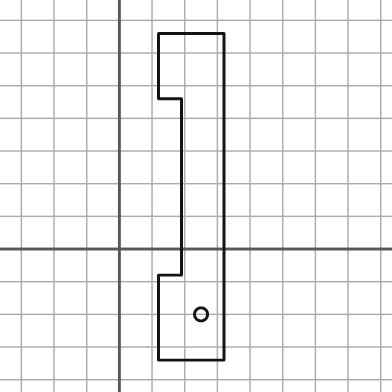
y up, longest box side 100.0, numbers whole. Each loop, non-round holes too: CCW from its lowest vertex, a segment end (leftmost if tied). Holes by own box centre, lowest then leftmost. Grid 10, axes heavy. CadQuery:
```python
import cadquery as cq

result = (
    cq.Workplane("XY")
    .moveTo(12.0, -34.0)
    .lineTo(32.0, -34.0)
    .lineTo(32.0, 66.0)
    .lineTo(12.0, 66.0)
    .lineTo(12.0, 46.0)
    .lineTo(19.0, 46.0)
    .lineTo(19.0, -8.0)
    .lineTo(12.0, -8.0)
    .close()
    .moveTo(25.0, -20.0)
    .circle(2.0)
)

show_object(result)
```